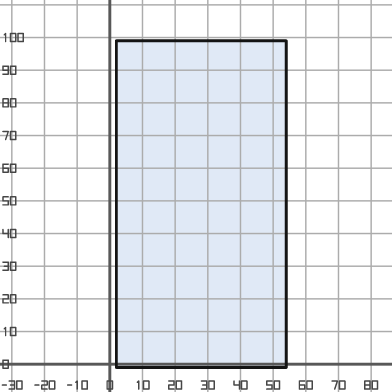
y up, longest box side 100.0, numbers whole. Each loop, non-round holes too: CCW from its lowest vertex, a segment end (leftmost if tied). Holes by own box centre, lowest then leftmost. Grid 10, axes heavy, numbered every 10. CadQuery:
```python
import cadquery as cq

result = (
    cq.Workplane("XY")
    .moveTo(2.0, -1.0)
    .lineTo(54.0, -1.0)
    .lineTo(54.0, 99.0)
    .lineTo(2.0, 99.0)
    .close()
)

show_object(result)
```